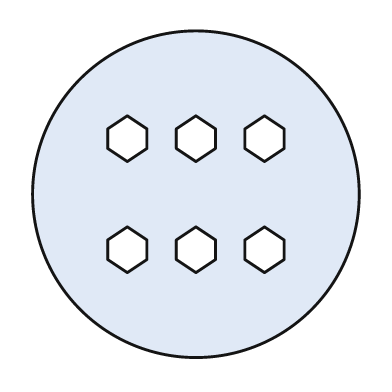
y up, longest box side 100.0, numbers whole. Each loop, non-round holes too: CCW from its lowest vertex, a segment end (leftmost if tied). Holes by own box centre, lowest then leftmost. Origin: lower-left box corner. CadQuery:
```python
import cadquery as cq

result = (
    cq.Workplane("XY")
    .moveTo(50.0, 50.0)
    .circle(50.0)
    .moveTo(29.0, 26.0)
    .lineTo(35.0, 30.0)
    .lineTo(35.0, 36.0)
    .lineTo(29.0, 40.0)
    .lineTo(23.0, 36.0)
    .lineTo(23.0, 30.0)
    .close()
    .moveTo(50.0, 26.0)
    .lineTo(56.0, 30.0)
    .lineTo(56.0, 36.0)
    .lineTo(50.0, 40.0)
    .lineTo(44.0, 36.0)
    .lineTo(44.0, 30.0)
    .close()
    .moveTo(71.0, 26.0)
    .lineTo(77.0, 30.0)
    .lineTo(77.0, 36.0)
    .lineTo(71.0, 40.0)
    .lineTo(65.0, 36.0)
    .lineTo(65.0, 30.0)
    .close()
    .moveTo(29.0, 60.0)
    .lineTo(35.0, 64.0)
    .lineTo(35.0, 70.0)
    .lineTo(29.0, 74.0)
    .lineTo(23.0, 70.0)
    .lineTo(23.0, 64.0)
    .close()
    .moveTo(50.0, 60.0)
    .lineTo(56.0, 64.0)
    .lineTo(56.0, 70.0)
    .lineTo(50.0, 74.0)
    .lineTo(44.0, 70.0)
    .lineTo(44.0, 64.0)
    .close()
    .moveTo(71.0, 60.0)
    .lineTo(77.0, 64.0)
    .lineTo(77.0, 70.0)
    .lineTo(71.0, 74.0)
    .lineTo(65.0, 70.0)
    .lineTo(65.0, 64.0)
    .close()
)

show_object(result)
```